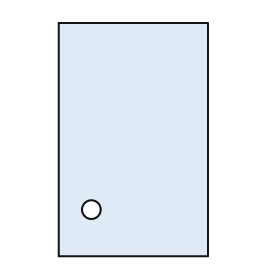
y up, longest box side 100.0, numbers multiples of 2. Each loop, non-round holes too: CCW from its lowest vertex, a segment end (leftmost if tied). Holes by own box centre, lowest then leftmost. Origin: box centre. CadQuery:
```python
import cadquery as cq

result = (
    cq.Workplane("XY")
    .moveTo(-32.0, -50.0)
    .lineTo(32.0, -50.0)
    .lineTo(32.0, 50.0)
    .lineTo(-32.0, 50.0)
    .close()
    .moveTo(-18.0, -30.0)
    .circle(4.0)
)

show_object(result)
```